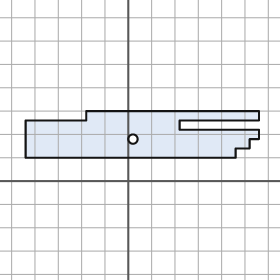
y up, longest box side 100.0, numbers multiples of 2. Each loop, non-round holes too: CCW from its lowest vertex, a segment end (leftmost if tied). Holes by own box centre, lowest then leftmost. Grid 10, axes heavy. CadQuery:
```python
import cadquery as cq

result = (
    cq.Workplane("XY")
    .moveTo(-44.0, 10.0)
    .lineTo(46.0, 10.0)
    .lineTo(46.0, 14.0)
    .lineTo(52.0, 14.0)
    .lineTo(52.0, 18.0)
    .lineTo(56.0, 18.0)
    .lineTo(56.0, 22.0)
    .lineTo(22.0, 22.0)
    .lineTo(22.0, 26.0)
    .lineTo(56.0, 26.0)
    .lineTo(56.0, 30.0)
    .lineTo(-18.0, 30.0)
    .lineTo(-18.0, 26.0)
    .lineTo(-44.0, 26.0)
    .close()
    .moveTo(2.0, 18.0)
    .circle(2.0)
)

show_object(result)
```